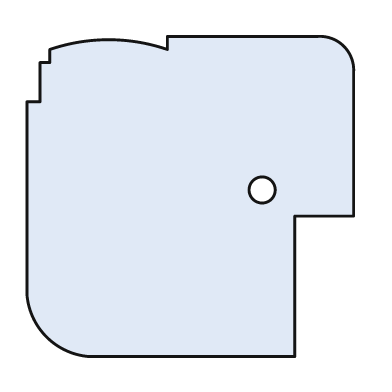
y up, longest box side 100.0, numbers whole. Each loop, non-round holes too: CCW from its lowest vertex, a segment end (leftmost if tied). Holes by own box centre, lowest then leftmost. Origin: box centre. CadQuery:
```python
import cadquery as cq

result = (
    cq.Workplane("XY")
    .moveTo(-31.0, -49.0)
    .lineTo(32.0, -49.0)
    .lineTo(32.0, -6.0)
    .lineTo(50.0, -6.0)
    .lineTo(50.0, 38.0)
    .threePointArc((47.0, 46.0), (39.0, 49.0))
    .lineTo(-7.0, 49.0)
    .lineTo(-7.0, 45.0)
    .threePointArc((-25.0, 48.0), (-43.0, 45.0))
    .lineTo(-43.0, 41.0)
    .lineTo(-46.0, 41.0)
    .lineTo(-46.0, 29.0)
    .lineTo(-50.0, 29.0)
    .lineTo(-50.0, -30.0)
    .threePointArc((-44.0, -43.0), (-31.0, -49.0))
    .close()
    .moveTo(22.0, 2.0)
    .circle(4.0)
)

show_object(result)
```